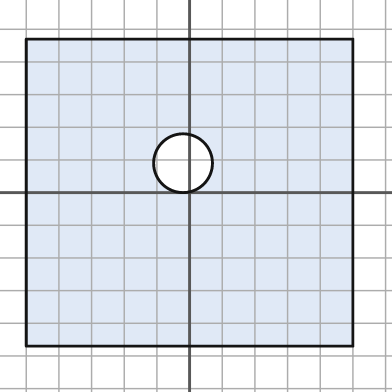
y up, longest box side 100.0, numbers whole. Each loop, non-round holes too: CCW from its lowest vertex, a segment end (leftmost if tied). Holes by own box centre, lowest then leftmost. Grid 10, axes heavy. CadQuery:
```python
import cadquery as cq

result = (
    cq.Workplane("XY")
    .moveTo(-50.0, -47.0)
    .lineTo(50.0, -47.0)
    .lineTo(50.0, 47.0)
    .lineTo(-50.0, 47.0)
    .close()
    .moveTo(-2.0, 9.0)
    .circle(9.0)
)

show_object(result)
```